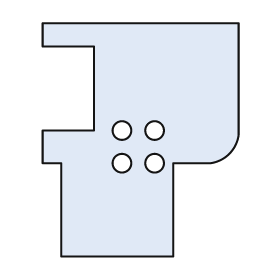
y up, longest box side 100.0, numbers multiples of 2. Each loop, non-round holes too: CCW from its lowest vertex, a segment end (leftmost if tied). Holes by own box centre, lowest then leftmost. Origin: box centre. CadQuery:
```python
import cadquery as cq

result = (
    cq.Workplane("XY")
    .moveTo(-34.0, -50.0)
    .lineTo(14.0, -50.0)
    .lineTo(14.0, -10.0)
    .lineTo(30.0, -10.0)
    .threePointArc((38.0, -6.0), (42.0, 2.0))
    .lineTo(42.0, 50.0)
    .lineTo(-42.0, 50.0)
    .lineTo(-42.0, 40.0)
    .lineTo(-20.0, 40.0)
    .lineTo(-20.0, 4.0)
    .lineTo(-42.0, 4.0)
    .lineTo(-42.0, -10.0)
    .lineTo(-34.0, -10.0)
    .close()
    .moveTo(-8.0, -10.0)
    .circle(4.0)
    .moveTo(6.0, -10.0)
    .circle(4.0)
    .moveTo(-8.0, 4.0)
    .circle(4.0)
    .moveTo(6.0, 4.0)
    .circle(4.0)
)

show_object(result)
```